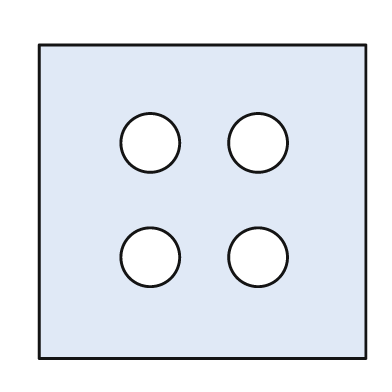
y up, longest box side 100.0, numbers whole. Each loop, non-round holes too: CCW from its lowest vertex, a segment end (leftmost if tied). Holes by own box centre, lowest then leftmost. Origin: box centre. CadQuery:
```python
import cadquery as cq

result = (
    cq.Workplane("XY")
    .moveTo(-50.0, -48.0)
    .lineTo(50.0, -48.0)
    .lineTo(50.0, 48.0)
    .lineTo(-50.0, 48.0)
    .close()
    .moveTo(-16.0, -17.0)
    .circle(9.0)
    .moveTo(17.0, -17.0)
    .circle(9.0)
    .moveTo(-16.0, 18.0)
    .circle(9.0)
    .moveTo(17.0, 18.0)
    .circle(9.0)
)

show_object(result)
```